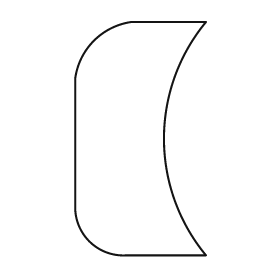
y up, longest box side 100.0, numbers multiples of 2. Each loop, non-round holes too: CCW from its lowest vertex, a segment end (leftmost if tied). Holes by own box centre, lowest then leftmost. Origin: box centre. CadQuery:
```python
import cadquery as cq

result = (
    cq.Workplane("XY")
    .moveTo(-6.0, -50.0)
    .lineTo(28.0, -50.0)
    .threePointArc((10.0, 0.0), (28.0, 50.0))
    .lineTo(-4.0, 50.0)
    .threePointArc((-20.0, 42.0), (-28.0, 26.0))
    .lineTo(-28.0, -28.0)
    .threePointArc((-22.0, -44.0), (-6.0, -50.0))
    .close()
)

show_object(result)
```